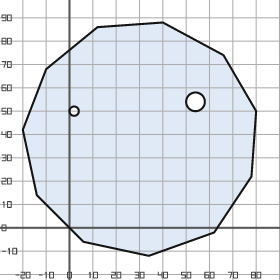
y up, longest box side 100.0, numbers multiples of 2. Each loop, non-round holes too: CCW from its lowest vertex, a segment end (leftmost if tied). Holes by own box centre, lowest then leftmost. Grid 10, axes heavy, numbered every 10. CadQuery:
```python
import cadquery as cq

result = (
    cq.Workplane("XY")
    .moveTo(34.0, -12.0)
    .lineTo(62.0, -2.0)
    .lineTo(78.0, 22.0)
    .lineTo(80.0, 50.0)
    .lineTo(66.0, 74.0)
    .lineTo(40.0, 88.0)
    .lineTo(12.0, 86.0)
    .lineTo(-10.0, 68.0)
    .lineTo(-20.0, 42.0)
    .lineTo(-14.0, 14.0)
    .lineTo(6.0, -6.0)
    .close()
    .moveTo(2.0, 50.0)
    .circle(2.0)
    .moveTo(54.0, 54.0)
    .circle(4.0)
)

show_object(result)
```